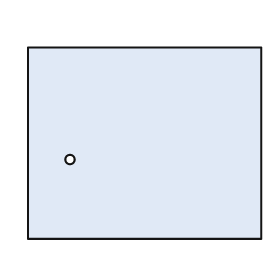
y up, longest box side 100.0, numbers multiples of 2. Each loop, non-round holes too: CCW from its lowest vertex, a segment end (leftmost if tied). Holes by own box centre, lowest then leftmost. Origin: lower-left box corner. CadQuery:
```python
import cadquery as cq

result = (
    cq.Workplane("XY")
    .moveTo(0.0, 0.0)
    .lineTo(100.0, 0.0)
    .lineTo(100.0, 82.0)
    .lineTo(0.0, 82.0)
    .close()
    .moveTo(18.0, 34.0)
    .circle(2.0)
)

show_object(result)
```